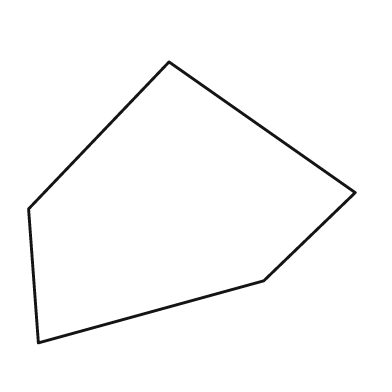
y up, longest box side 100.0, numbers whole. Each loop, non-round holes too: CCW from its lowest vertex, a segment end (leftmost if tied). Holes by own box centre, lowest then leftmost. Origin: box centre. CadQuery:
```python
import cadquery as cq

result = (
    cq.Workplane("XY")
    .moveTo(-47.0, -43.0)
    .lineTo(22.0, -24.0)
    .lineTo(50.0, 3.0)
    .lineTo(-7.0, 43.0)
    .lineTo(-50.0, -2.0)
    .close()
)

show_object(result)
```